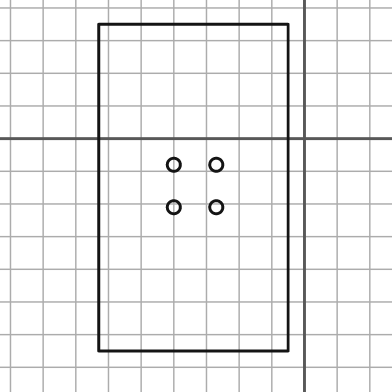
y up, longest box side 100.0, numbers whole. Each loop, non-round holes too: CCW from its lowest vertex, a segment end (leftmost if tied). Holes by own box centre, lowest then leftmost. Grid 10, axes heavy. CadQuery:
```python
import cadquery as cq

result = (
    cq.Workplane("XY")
    .moveTo(-63.0, -65.0)
    .lineTo(-5.0, -65.0)
    .lineTo(-5.0, 35.0)
    .lineTo(-63.0, 35.0)
    .close()
    .moveTo(-40.0, -21.0)
    .circle(2.0)
    .moveTo(-27.0, -21.0)
    .circle(2.0)
    .moveTo(-40.0, -8.0)
    .circle(2.0)
    .moveTo(-27.0, -8.0)
    .circle(2.0)
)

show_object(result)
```